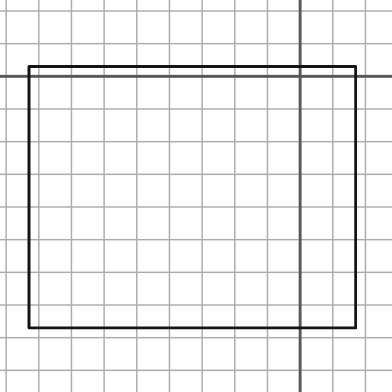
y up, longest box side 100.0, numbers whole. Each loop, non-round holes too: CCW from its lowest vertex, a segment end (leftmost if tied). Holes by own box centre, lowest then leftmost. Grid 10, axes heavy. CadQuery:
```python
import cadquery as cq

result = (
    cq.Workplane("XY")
    .moveTo(-83.0, -77.0)
    .lineTo(17.0, -77.0)
    .lineTo(17.0, 3.0)
    .lineTo(-83.0, 3.0)
    .close()
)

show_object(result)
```